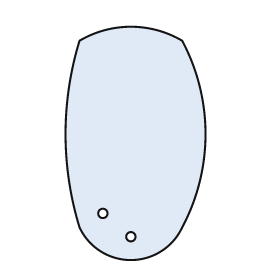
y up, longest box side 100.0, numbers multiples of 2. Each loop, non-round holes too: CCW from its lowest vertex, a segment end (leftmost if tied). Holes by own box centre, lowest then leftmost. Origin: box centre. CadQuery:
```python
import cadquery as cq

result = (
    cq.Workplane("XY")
    .moveTo(-24.0, -36.0)
    .threePointArc((-2.0, -50.0), (20.0, -36.0))
    .threePointArc((30.0, 4.0), (20.0, 44.0))
    .threePointArc((-2.0, 50.0), (-24.0, 44.0))
    .threePointArc((-30.0, 4.0), (-24.0, -36.0))
    .close()
    .moveTo(-2.0, -40.0)
    .circle(2.0)
    .moveTo(-14.0, -30.0)
    .circle(2.0)
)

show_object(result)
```